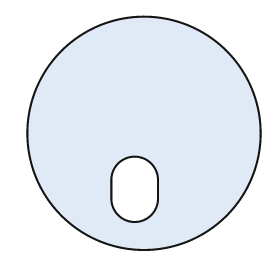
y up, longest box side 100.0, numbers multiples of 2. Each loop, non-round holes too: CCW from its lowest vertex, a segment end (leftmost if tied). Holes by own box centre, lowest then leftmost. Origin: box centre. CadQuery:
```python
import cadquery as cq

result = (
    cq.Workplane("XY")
    .moveTo(0.0, 0.0)
    .circle(50.0)
    .moveTo(-14.0, -28.0)
    .threePointArc((-4.0, -38.0), (6.0, -28.0))
    .lineTo(6.0, -20.0)
    .threePointArc((-4.0, -10.0), (-14.0, -20.0))
    .close()
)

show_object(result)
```